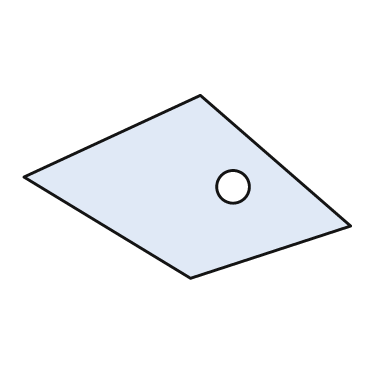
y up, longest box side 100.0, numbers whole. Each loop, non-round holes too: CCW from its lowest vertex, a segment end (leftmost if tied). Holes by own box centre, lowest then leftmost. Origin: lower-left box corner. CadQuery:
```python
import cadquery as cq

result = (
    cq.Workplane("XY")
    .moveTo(51.0, 0.0)
    .lineTo(100.0, 16.0)
    .lineTo(54.0, 56.0)
    .lineTo(0.0, 31.0)
    .close()
    .moveTo(64.0, 28.0)
    .circle(5.0)
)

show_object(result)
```